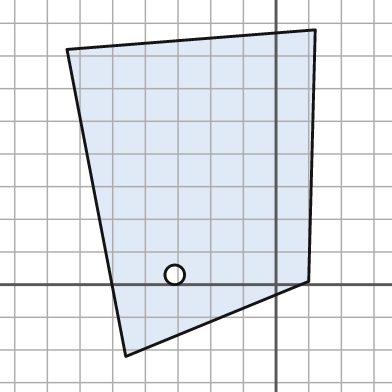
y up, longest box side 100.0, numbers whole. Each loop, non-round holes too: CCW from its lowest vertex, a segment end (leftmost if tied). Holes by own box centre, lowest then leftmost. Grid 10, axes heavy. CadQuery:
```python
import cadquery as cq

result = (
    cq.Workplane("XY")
    .moveTo(-46.0, -22.0)
    .lineTo(10.0, 1.0)
    .lineTo(12.0, 78.0)
    .lineTo(-64.0, 72.0)
    .close()
    .moveTo(-31.0, 3.0)
    .circle(3.0)
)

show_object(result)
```